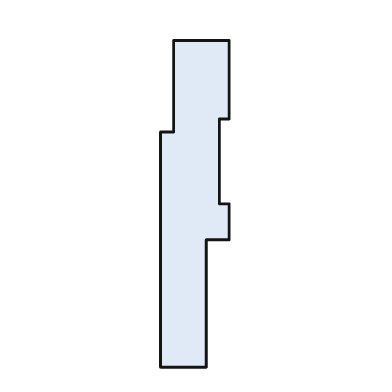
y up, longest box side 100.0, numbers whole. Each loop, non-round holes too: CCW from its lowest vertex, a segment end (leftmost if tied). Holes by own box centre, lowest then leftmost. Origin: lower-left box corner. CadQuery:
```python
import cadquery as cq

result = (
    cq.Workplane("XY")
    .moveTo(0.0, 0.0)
    .lineTo(14.0, 0.0)
    .lineTo(14.0, 39.0)
    .lineTo(21.0, 39.0)
    .lineTo(21.0, 50.0)
    .lineTo(18.0, 50.0)
    .lineTo(18.0, 76.0)
    .lineTo(21.0, 76.0)
    .lineTo(21.0, 100.0)
    .lineTo(4.0, 100.0)
    .lineTo(4.0, 72.0)
    .lineTo(0.0, 72.0)
    .close()
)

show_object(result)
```